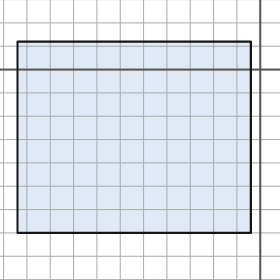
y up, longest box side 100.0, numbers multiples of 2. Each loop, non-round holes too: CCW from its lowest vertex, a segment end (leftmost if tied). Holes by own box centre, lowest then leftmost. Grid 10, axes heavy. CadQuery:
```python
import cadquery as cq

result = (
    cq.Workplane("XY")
    .moveTo(-104.0, -70.0)
    .lineTo(-4.0, -70.0)
    .lineTo(-4.0, 12.0)
    .lineTo(-104.0, 12.0)
    .close()
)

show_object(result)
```